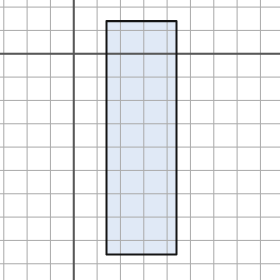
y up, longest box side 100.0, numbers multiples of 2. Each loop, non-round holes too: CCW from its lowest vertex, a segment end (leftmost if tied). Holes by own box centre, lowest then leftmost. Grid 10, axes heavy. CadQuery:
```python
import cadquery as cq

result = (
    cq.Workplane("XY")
    .moveTo(14.0, -86.0)
    .lineTo(44.0, -86.0)
    .lineTo(44.0, 14.0)
    .lineTo(14.0, 14.0)
    .close()
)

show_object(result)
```